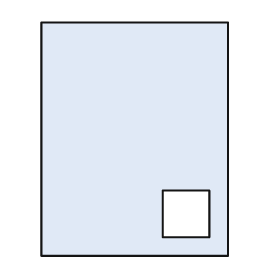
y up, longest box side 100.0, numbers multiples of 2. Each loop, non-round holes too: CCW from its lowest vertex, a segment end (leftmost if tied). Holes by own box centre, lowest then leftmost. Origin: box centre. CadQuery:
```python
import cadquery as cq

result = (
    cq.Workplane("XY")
    .moveTo(-40.0, -50.0)
    .lineTo(40.0, -50.0)
    .lineTo(40.0, 50.0)
    .lineTo(-40.0, 50.0)
    .close()
    .moveTo(12.0, -42.0)
    .lineTo(32.0, -42.0)
    .lineTo(32.0, -22.0)
    .lineTo(12.0, -22.0)
    .close()
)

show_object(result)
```